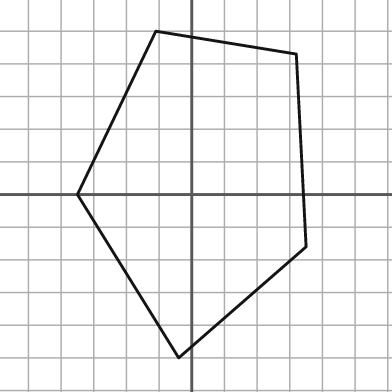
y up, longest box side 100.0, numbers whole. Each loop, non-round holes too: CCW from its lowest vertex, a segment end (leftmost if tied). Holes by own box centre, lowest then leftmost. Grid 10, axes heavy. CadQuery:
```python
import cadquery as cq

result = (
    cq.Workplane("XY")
    .moveTo(-4.0, -50.0)
    .lineTo(35.0, -16.0)
    .lineTo(32.0, 43.0)
    .lineTo(-11.0, 50.0)
    .lineTo(-35.0, 0.0)
    .close()
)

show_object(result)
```